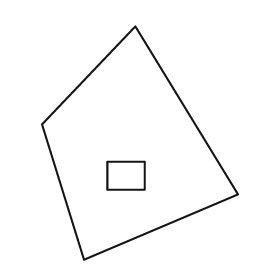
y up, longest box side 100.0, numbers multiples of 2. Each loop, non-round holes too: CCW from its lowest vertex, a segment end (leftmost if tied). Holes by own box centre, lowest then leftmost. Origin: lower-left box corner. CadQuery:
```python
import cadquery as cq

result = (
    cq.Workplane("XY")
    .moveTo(18.0, 0.0)
    .lineTo(84.0, 28.0)
    .lineTo(40.0, 100.0)
    .lineTo(0.0, 58.0)
    .close()
    .moveTo(28.0, 30.0)
    .lineTo(44.0, 30.0)
    .lineTo(44.0, 42.0)
    .lineTo(28.0, 42.0)
    .close()
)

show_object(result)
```